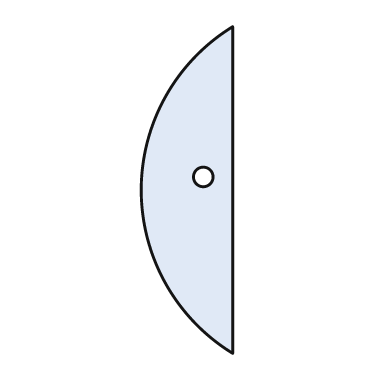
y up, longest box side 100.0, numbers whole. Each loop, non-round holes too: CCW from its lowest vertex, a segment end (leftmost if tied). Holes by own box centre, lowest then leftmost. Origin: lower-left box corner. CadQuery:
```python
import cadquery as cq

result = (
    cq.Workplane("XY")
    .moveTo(28.0, 0.0)
    .lineTo(28.0, 100.0)
    .threePointArc((0.0, 50.0), (28.0, 0.0))
    .close()
    .moveTo(19.0, 54.0)
    .circle(3.0)
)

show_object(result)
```